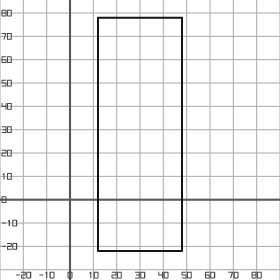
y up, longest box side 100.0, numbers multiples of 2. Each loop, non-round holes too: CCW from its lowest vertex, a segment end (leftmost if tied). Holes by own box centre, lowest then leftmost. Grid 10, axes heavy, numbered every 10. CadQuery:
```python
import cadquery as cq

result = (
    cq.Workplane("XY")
    .moveTo(12.0, -22.0)
    .lineTo(48.0, -22.0)
    .lineTo(48.0, 78.0)
    .lineTo(12.0, 78.0)
    .close()
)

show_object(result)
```